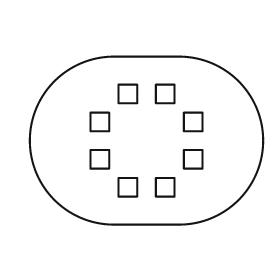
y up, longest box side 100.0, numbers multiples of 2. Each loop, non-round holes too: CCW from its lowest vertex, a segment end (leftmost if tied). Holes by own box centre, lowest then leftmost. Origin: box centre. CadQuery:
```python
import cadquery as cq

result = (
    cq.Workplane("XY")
    .moveTo(-14.0, -36.0)
    .lineTo(14.0, -36.0)
    .threePointArc((50.0, 0.0), (14.0, 36.0))
    .lineTo(-14.0, 36.0)
    .threePointArc((-50.0, 0.0), (-14.0, -36.0))
    .close()
    .moveTo(-12.0, -24.0)
    .lineTo(-4.0, -24.0)
    .lineTo(-4.0, -16.0)
    .lineTo(-12.0, -16.0)
    .close()
    .moveTo(4.0, -24.0)
    .lineTo(12.0, -24.0)
    .lineTo(12.0, -16.0)
    .lineTo(4.0, -16.0)
    .close()
    .moveTo(-24.0, -12.0)
    .lineTo(-16.0, -12.0)
    .lineTo(-16.0, -4.0)
    .lineTo(-24.0, -4.0)
    .close()
    .moveTo(16.0, -12.0)
    .lineTo(24.0, -12.0)
    .lineTo(24.0, -4.0)
    .lineTo(16.0, -4.0)
    .close()
    .moveTo(-24.0, 4.0)
    .lineTo(-16.0, 4.0)
    .lineTo(-16.0, 12.0)
    .lineTo(-24.0, 12.0)
    .close()
    .moveTo(16.0, 4.0)
    .lineTo(24.0, 4.0)
    .lineTo(24.0, 12.0)
    .lineTo(16.0, 12.0)
    .close()
    .moveTo(-12.0, 16.0)
    .lineTo(-4.0, 16.0)
    .lineTo(-4.0, 24.0)
    .lineTo(-12.0, 24.0)
    .close()
    .moveTo(4.0, 16.0)
    .lineTo(12.0, 16.0)
    .lineTo(12.0, 24.0)
    .lineTo(4.0, 24.0)
    .close()
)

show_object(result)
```